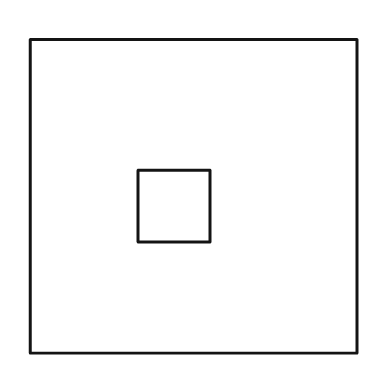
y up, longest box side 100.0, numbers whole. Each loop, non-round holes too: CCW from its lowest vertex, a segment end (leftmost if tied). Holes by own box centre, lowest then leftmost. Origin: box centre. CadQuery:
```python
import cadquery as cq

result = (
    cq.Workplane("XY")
    .moveTo(-50.0, -48.0)
    .lineTo(50.0, -48.0)
    .lineTo(50.0, 48.0)
    .lineTo(-50.0, 48.0)
    .close()
    .moveTo(-17.0, -14.0)
    .lineTo(5.0, -14.0)
    .lineTo(5.0, 8.0)
    .lineTo(-17.0, 8.0)
    .close()
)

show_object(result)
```